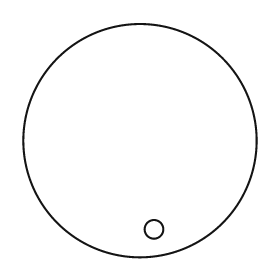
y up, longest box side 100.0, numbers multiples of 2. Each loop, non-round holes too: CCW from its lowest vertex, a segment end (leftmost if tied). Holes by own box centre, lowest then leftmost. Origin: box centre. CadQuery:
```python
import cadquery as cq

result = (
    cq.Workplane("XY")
    .moveTo(0.0, 0.0)
    .circle(50.0)
    .moveTo(6.0, -38.0)
    .circle(4.0)
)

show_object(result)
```